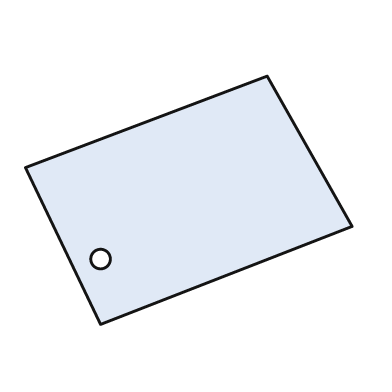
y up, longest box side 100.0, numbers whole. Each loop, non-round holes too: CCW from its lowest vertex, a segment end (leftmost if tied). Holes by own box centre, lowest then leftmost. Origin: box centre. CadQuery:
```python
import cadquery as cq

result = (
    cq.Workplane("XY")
    .moveTo(-27.0, -38.0)
    .lineTo(50.0, -8.0)
    .lineTo(24.0, 38.0)
    .lineTo(-50.0, 10.0)
    .close()
    .moveTo(-27.0, -18.0)
    .circle(3.0)
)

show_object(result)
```